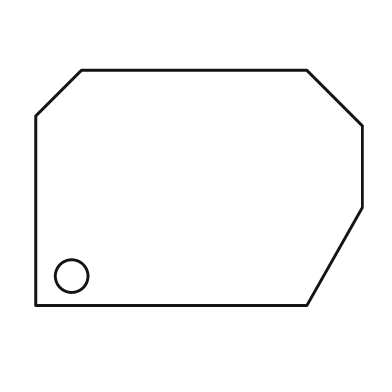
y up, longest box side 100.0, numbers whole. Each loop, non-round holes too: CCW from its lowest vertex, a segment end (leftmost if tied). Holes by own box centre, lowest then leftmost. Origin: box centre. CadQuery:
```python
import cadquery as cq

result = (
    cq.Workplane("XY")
    .moveTo(-50.0, -36.0)
    .lineTo(33.0, -36.0)
    .lineTo(50.0, -6.0)
    .lineTo(50.0, 19.0)
    .lineTo(33.0, 36.0)
    .lineTo(-36.0, 36.0)
    .lineTo(-50.0, 22.0)
    .close()
    .moveTo(-39.0, -27.0)
    .circle(5.0)
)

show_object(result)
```